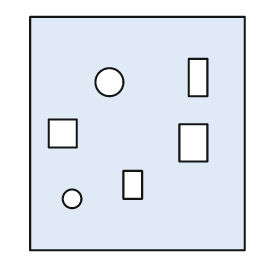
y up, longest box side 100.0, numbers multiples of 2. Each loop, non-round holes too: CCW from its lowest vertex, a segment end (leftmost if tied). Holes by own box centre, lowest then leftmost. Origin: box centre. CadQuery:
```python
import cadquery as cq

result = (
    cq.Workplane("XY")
    .moveTo(-46.0, -50.0)
    .lineTo(46.0, -50.0)
    .lineTo(46.0, 50.0)
    .lineTo(-46.0, 50.0)
    .close()
    .moveTo(-28.0, -28.0)
    .circle(4.0)
    .moveTo(-6.0, -28.0)
    .lineTo(2.0, -28.0)
    .lineTo(2.0, -16.0)
    .lineTo(-6.0, -16.0)
    .close()
    .moveTo(18.0, -12.0)
    .lineTo(30.0, -12.0)
    .lineTo(30.0, 4.0)
    .lineTo(18.0, 4.0)
    .close()
    .moveTo(-38.0, -6.0)
    .lineTo(-26.0, -6.0)
    .lineTo(-26.0, 6.0)
    .lineTo(-38.0, 6.0)
    .close()
    .moveTo(-12.0, 22.0)
    .circle(6.0)
    .moveTo(22.0, 16.0)
    .lineTo(30.0, 16.0)
    .lineTo(30.0, 32.0)
    .lineTo(22.0, 32.0)
    .close()
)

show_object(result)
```